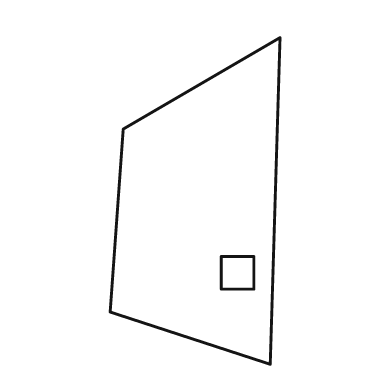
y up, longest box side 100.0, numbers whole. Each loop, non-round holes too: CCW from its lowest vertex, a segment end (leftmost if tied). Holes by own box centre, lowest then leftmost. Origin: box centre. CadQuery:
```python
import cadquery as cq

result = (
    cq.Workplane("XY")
    .moveTo(23.0, -50.0)
    .lineTo(26.0, 50.0)
    .lineTo(-22.0, 22.0)
    .lineTo(-26.0, -34.0)
    .close()
    .moveTo(8.0, -27.0)
    .lineTo(18.0, -27.0)
    .lineTo(18.0, -17.0)
    .lineTo(8.0, -17.0)
    .close()
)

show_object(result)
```